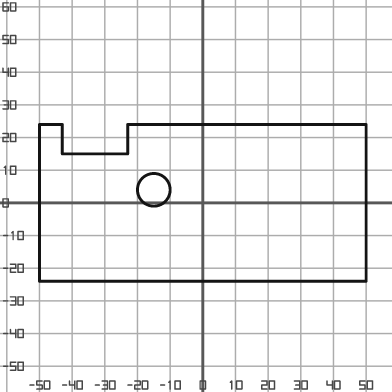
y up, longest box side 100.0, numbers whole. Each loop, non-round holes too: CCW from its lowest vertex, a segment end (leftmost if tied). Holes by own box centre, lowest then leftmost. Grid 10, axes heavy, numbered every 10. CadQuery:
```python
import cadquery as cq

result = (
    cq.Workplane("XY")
    .moveTo(-50.0, -24.0)
    .lineTo(50.0, -24.0)
    .lineTo(50.0, 24.0)
    .lineTo(-23.0, 24.0)
    .lineTo(-23.0, 15.0)
    .lineTo(-43.0, 15.0)
    .lineTo(-43.0, 24.0)
    .lineTo(-50.0, 24.0)
    .close()
    .moveTo(-15.0, 4.0)
    .circle(5.0)
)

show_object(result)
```